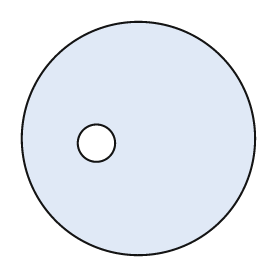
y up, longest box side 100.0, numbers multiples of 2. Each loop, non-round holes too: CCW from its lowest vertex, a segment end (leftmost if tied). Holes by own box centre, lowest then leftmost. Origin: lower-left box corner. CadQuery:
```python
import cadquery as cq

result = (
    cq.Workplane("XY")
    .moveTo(50.0, 50.0)
    .circle(50.0)
    .moveTo(32.0, 48.0)
    .circle(8.0)
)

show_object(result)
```